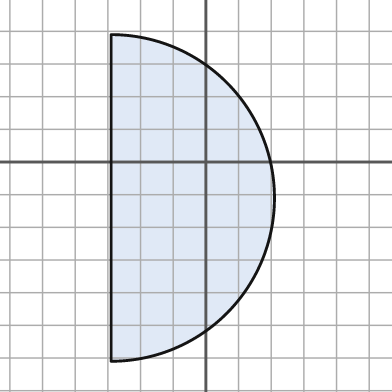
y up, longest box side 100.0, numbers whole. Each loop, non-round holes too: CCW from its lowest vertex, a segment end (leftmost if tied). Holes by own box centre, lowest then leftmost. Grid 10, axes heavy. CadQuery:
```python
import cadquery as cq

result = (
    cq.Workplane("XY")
    .moveTo(-29.0, -61.0)
    .threePointArc((21.0, -11.0), (-29.0, 39.0))
    .close()
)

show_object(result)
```